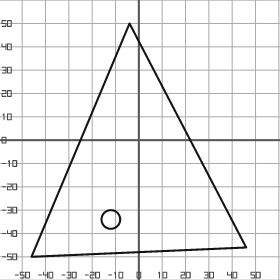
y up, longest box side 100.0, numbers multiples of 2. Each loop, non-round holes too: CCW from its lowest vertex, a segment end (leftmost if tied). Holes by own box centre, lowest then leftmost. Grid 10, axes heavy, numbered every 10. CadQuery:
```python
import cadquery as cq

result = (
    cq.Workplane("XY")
    .moveTo(-46.0, -50.0)
    .lineTo(46.0, -46.0)
    .lineTo(-4.0, 50.0)
    .close()
    .moveTo(-12.0, -34.0)
    .circle(4.0)
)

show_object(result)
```